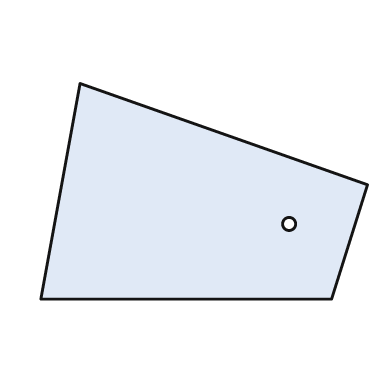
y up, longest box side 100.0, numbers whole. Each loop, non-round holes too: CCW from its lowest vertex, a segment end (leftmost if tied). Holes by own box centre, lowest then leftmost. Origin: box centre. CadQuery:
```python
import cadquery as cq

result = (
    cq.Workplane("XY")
    .moveTo(-50.0, -33.0)
    .lineTo(39.0, -33.0)
    .lineTo(50.0, 2.0)
    .lineTo(-38.0, 33.0)
    .close()
    .moveTo(26.0, -10.0)
    .circle(2.0)
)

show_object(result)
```